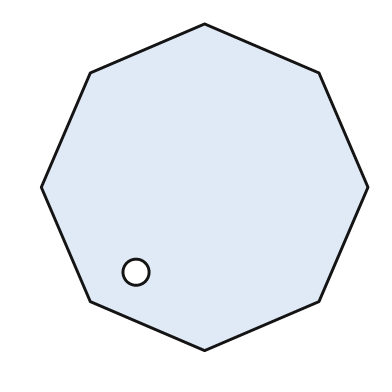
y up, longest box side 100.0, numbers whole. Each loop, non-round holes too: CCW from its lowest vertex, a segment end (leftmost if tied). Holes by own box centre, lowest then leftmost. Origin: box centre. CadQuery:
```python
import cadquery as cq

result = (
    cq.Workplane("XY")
    .moveTo(0.0, -50.0)
    .lineTo(35.0, -35.0)
    .lineTo(50.0, 0.0)
    .lineTo(35.0, 35.0)
    .lineTo(0.0, 50.0)
    .lineTo(-35.0, 35.0)
    .lineTo(-50.0, 0.0)
    .lineTo(-35.0, -35.0)
    .close()
    .moveTo(-21.0, -26.0)
    .circle(4.0)
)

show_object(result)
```